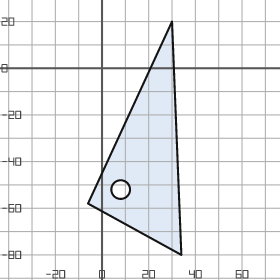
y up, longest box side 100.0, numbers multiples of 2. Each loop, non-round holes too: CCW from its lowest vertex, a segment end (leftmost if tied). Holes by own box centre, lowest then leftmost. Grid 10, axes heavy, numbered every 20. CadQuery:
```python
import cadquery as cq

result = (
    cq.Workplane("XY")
    .moveTo(34.0, -80.0)
    .lineTo(30.0, 20.0)
    .lineTo(-6.0, -58.0)
    .close()
    .moveTo(8.0, -52.0)
    .circle(4.0)
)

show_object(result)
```